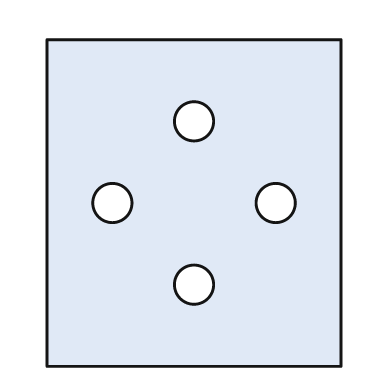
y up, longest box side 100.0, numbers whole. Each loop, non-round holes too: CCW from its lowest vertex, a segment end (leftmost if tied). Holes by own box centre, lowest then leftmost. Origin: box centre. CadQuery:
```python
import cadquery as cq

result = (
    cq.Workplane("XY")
    .moveTo(-45.0, -50.0)
    .lineTo(45.0, -50.0)
    .lineTo(45.0, 50.0)
    .lineTo(-45.0, 50.0)
    .close()
    .moveTo(0.0, -25.0)
    .circle(6.0)
    .moveTo(-25.0, 0.0)
    .circle(6.0)
    .moveTo(25.0, 0.0)
    .circle(6.0)
    .moveTo(0.0, 25.0)
    .circle(6.0)
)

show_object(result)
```